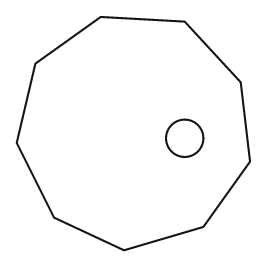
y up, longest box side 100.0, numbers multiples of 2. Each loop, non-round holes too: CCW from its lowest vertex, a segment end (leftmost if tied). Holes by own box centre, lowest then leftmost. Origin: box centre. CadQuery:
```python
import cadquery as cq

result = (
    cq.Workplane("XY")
    .moveTo(-4.0, -50.0)
    .lineTo(30.0, -40.0)
    .lineTo(50.0, -12.0)
    .lineTo(46.0, 22.0)
    .lineTo(22.0, 48.0)
    .lineTo(-14.0, 50.0)
    .lineTo(-42.0, 30.0)
    .lineTo(-50.0, -4.0)
    .lineTo(-34.0, -36.0)
    .close()
    .moveTo(22.0, -2.0)
    .circle(8.0)
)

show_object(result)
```